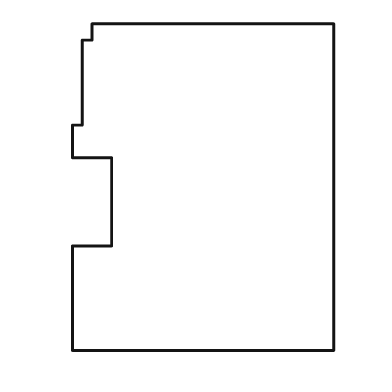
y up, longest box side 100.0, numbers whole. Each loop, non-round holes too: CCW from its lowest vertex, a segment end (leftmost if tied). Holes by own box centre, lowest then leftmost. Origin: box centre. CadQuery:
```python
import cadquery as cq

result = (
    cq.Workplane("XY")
    .moveTo(-40.0, -50.0)
    .lineTo(40.0, -50.0)
    .lineTo(40.0, 50.0)
    .lineTo(-34.0, 50.0)
    .lineTo(-34.0, 45.0)
    .lineTo(-37.0, 45.0)
    .lineTo(-37.0, 19.0)
    .lineTo(-40.0, 19.0)
    .lineTo(-40.0, 9.0)
    .lineTo(-28.0, 9.0)
    .lineTo(-28.0, -18.0)
    .lineTo(-40.0, -18.0)
    .close()
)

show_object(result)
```